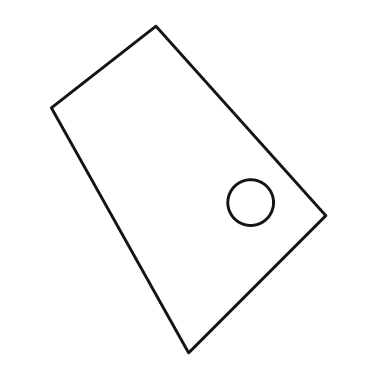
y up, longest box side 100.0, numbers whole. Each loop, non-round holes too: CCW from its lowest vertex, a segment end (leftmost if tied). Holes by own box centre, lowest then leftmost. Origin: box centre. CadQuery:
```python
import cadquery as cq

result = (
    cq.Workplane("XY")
    .moveTo(0.0, -50.0)
    .lineTo(42.0, -8.0)
    .lineTo(-10.0, 50.0)
    .lineTo(-42.0, 25.0)
    .close()
    .moveTo(19.0, -4.0)
    .circle(7.0)
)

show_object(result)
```